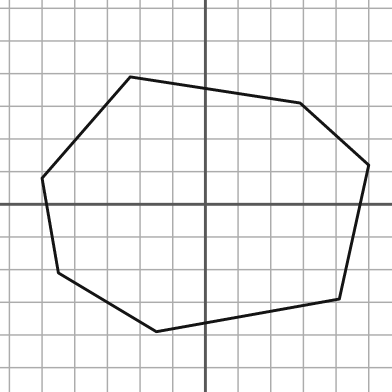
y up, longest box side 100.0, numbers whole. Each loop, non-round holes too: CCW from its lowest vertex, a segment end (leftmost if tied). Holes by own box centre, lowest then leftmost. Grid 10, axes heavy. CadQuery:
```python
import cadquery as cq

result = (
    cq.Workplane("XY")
    .moveTo(-15.0, -39.0)
    .lineTo(41.0, -29.0)
    .lineTo(50.0, 12.0)
    .lineTo(29.0, 31.0)
    .lineTo(-23.0, 39.0)
    .lineTo(-50.0, 8.0)
    .lineTo(-45.0, -21.0)
    .close()
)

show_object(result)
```